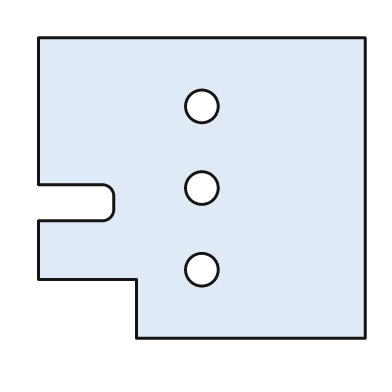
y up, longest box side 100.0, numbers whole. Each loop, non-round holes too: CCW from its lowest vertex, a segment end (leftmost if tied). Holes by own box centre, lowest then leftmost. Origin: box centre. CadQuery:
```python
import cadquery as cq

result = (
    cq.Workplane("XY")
    .moveTo(-20.0, -46.0)
    .lineTo(50.0, -46.0)
    .lineTo(50.0, 46.0)
    .lineTo(-50.0, 46.0)
    .lineTo(-50.0, 1.0)
    .lineTo(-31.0, 1.0)
    .threePointArc((-28.0, 0.0), (-27.0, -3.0))
    .lineTo(-27.0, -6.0)
    .threePointArc((-28.0, -9.0), (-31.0, -10.0))
    .lineTo(-50.0, -10.0)
    .lineTo(-50.0, -28.0)
    .lineTo(-20.0, -28.0)
    .close()
    .moveTo(0.0, -25.0)
    .circle(5.0)
    .moveTo(0.0, 0.0)
    .circle(5.0)
    .moveTo(0.0, 25.0)
    .circle(5.0)
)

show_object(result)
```